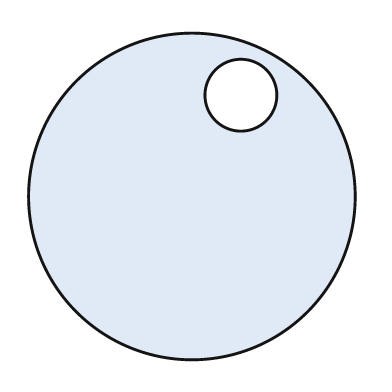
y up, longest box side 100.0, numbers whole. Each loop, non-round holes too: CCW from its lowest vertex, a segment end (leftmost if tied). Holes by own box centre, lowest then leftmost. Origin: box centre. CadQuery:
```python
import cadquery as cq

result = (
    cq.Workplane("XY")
    .moveTo(0.0, 0.0)
    .circle(50.0)
    .moveTo(15.0, 31.0)
    .circle(11.0)
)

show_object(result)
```